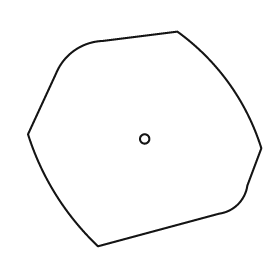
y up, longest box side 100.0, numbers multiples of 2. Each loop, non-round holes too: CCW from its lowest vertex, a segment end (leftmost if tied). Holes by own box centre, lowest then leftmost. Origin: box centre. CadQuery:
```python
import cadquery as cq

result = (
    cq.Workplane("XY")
    .moveTo(-20.0, -46.0)
    .lineTo(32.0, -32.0)
    .threePointArc((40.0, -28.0), (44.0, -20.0))
    .lineTo(50.0, -4.0)
    .threePointArc((36.0, 24.0), (14.0, 46.0))
    .lineTo(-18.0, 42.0)
    .threePointArc((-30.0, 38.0), (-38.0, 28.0))
    .lineTo(-50.0, 2.0)
    .threePointArc((-38.0, -24.0), (-20.0, -46.0))
    .close()
    .moveTo(0.0, 0.0)
    .circle(2.0)
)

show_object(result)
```